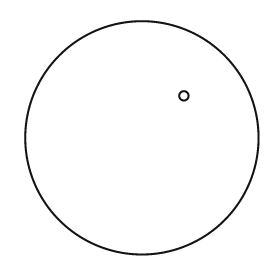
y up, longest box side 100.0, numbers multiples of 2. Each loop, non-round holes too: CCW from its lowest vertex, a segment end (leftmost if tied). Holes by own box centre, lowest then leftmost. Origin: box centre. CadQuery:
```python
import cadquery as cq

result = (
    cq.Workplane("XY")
    .moveTo(0.0, 0.0)
    .circle(50.0)
    .moveTo(18.0, 18.0)
    .circle(2.0)
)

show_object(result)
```